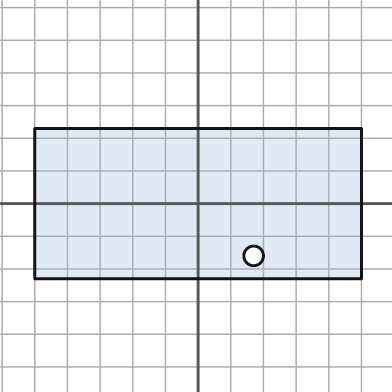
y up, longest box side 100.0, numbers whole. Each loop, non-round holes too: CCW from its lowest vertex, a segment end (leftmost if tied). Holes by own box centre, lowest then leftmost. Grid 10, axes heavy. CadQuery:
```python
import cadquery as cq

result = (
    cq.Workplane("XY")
    .moveTo(-50.0, -23.0)
    .lineTo(50.0, -23.0)
    .lineTo(50.0, 23.0)
    .lineTo(-50.0, 23.0)
    .close()
    .moveTo(17.0, -16.0)
    .circle(3.0)
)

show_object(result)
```